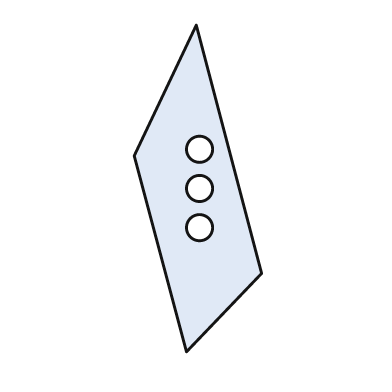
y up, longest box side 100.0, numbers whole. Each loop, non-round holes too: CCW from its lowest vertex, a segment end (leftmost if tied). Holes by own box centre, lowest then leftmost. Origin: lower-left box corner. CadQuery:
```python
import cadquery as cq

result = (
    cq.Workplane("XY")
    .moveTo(16.0, 0.0)
    .lineTo(39.0, 24.0)
    .lineTo(19.0, 100.0)
    .lineTo(0.0, 60.0)
    .close()
    .moveTo(20.0, 38.0)
    .circle(4.0)
    .moveTo(20.0, 50.0)
    .circle(4.0)
    .moveTo(20.0, 62.0)
    .circle(4.0)
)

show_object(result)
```